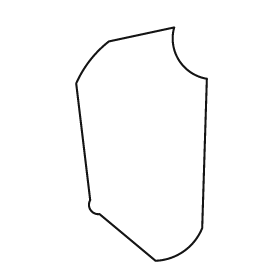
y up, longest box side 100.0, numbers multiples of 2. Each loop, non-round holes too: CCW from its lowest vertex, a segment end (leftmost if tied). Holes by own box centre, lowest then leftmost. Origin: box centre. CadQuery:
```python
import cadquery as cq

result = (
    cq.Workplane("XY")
    .moveTo(6.0, -50.0)
    .threePointArc((18.0, -46.0), (26.0, -36.0))
    .lineTo(28.0, 28.0)
    .threePointArc((16.0, 36.0), (14.0, 50.0))
    .lineTo(-14.0, 44.0)
    .threePointArc((-22.0, 36.0), (-28.0, 26.0))
    .lineTo(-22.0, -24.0)
    .threePointArc((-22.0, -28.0), (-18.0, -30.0))
    .close()
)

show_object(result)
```